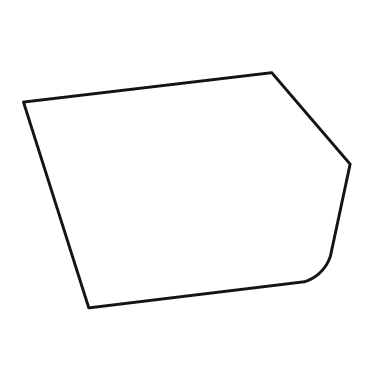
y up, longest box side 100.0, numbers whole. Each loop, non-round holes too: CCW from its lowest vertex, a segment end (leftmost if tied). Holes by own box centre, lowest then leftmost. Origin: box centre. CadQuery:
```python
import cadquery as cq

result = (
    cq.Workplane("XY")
    .moveTo(-30.0, -36.0)
    .lineTo(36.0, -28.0)
    .threePointArc((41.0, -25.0), (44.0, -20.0))
    .lineTo(50.0, 8.0)
    .lineTo(26.0, 36.0)
    .lineTo(-50.0, 27.0)
    .close()
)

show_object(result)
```